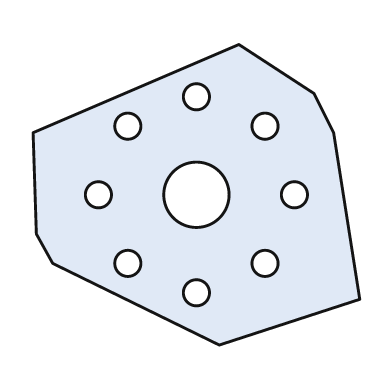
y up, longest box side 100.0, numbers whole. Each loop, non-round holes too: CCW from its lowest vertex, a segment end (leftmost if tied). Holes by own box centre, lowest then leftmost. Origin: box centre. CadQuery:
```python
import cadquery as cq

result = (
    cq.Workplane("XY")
    .moveTo(7.0, -46.0)
    .lineTo(50.0, -32.0)
    .lineTo(42.0, 19.0)
    .lineTo(36.0, 31.0)
    .lineTo(13.0, 46.0)
    .lineTo(-50.0, 19.0)
    .lineTo(-49.0, -12.0)
    .lineTo(-44.0, -21.0)
    .close()
    .moveTo(0.0, -30.0)
    .circle(4.0)
    .moveTo(-21.0, -21.0)
    .circle(4.0)
    .moveTo(21.0, -21.0)
    .circle(4.0)
    .moveTo(-30.0, 0.0)
    .circle(4.0)
    .moveTo(0.0, 0.0)
    .circle(10.0)
    .moveTo(30.0, 0.0)
    .circle(4.0)
    .moveTo(-21.0, 21.0)
    .circle(4.0)
    .moveTo(21.0, 21.0)
    .circle(4.0)
    .moveTo(0.0, 30.0)
    .circle(4.0)
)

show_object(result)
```